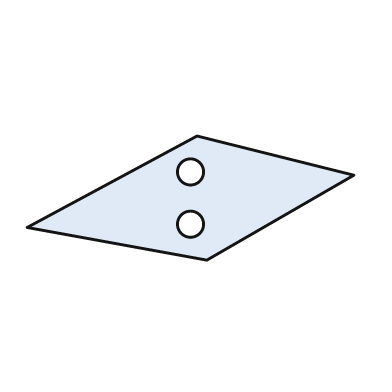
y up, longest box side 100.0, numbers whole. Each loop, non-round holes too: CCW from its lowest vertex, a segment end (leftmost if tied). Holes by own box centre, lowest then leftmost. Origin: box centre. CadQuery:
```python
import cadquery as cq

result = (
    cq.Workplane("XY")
    .moveTo(5.0, -19.0)
    .lineTo(50.0, 7.0)
    .lineTo(2.0, 19.0)
    .lineTo(-50.0, -9.0)
    .close()
    .moveTo(0.0, -8.0)
    .circle(4.0)
    .moveTo(0.0, 8.0)
    .circle(4.0)
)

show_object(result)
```